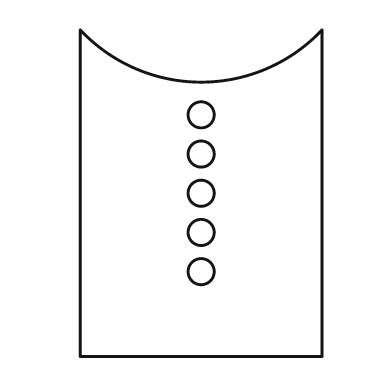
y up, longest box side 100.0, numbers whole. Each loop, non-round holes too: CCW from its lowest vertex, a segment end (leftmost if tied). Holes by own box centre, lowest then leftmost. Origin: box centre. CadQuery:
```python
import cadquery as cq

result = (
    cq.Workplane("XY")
    .moveTo(-37.0, -50.0)
    .lineTo(37.0, -50.0)
    .lineTo(37.0, 50.0)
    .threePointArc((0.0, 34.0), (-37.0, 50.0))
    .close()
    .moveTo(0.0, -24.0)
    .circle(4.0)
    .moveTo(0.0, -12.0)
    .circle(4.0)
    .moveTo(0.0, 0.0)
    .circle(4.0)
    .moveTo(0.0, 12.0)
    .circle(4.0)
    .moveTo(0.0, 24.0)
    .circle(4.0)
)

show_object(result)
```